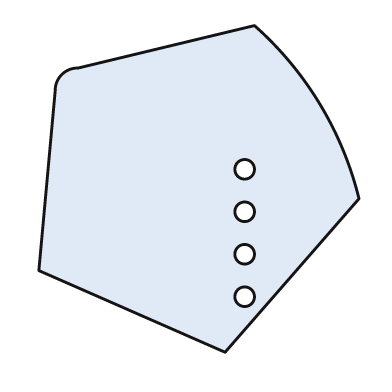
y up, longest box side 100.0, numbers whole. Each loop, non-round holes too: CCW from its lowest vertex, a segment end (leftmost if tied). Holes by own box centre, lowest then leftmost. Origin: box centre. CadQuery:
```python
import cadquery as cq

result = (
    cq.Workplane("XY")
    .moveTo(8.0, -50.0)
    .lineTo(49.0, -3.0)
    .threePointArc((37.0, 26.0), (17.0, 50.0))
    .lineTo(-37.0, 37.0)
    .threePointArc((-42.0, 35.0), (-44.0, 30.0))
    .lineTo(-49.0, -25.0)
    .close()
    .moveTo(14.0, -33.0)
    .circle(3.0)
    .moveTo(14.0, -20.0)
    .circle(3.0)
    .moveTo(14.0, -7.0)
    .circle(3.0)
    .moveTo(14.0, 6.0)
    .circle(3.0)
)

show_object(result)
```